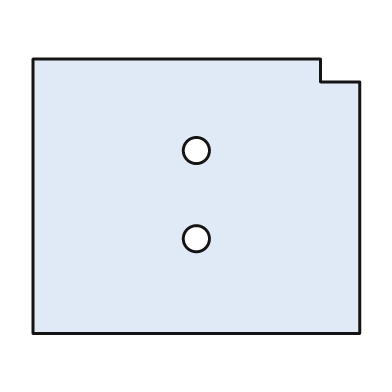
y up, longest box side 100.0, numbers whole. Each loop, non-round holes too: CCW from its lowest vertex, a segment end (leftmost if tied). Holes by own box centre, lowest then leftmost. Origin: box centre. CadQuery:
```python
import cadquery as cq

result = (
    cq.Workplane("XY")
    .moveTo(-50.0, -42.0)
    .lineTo(50.0, -42.0)
    .lineTo(50.0, 35.0)
    .lineTo(38.0, 35.0)
    .lineTo(38.0, 42.0)
    .lineTo(-50.0, 42.0)
    .close()
    .moveTo(0.0, -13.0)
    .circle(4.0)
    .moveTo(0.0, 14.0)
    .circle(4.0)
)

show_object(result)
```